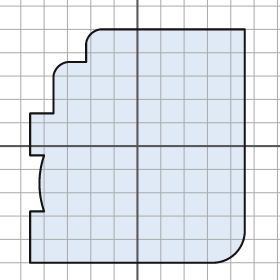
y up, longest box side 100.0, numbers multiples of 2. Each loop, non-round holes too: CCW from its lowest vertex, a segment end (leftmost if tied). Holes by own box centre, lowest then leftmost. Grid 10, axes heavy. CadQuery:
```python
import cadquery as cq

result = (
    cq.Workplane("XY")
    .moveTo(-46.0, -50.0)
    .lineTo(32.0, -50.0)
    .threePointArc((42.0, -46.0), (46.0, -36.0))
    .lineTo(46.0, 50.0)
    .lineTo(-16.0, 50.0)
    .threePointArc((-20.0, 48.0), (-22.0, 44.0))
    .lineTo(-22.0, 36.0)
    .lineTo(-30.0, 36.0)
    .threePointArc((-34.0, 34.0), (-36.0, 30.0))
    .lineTo(-36.0, 14.0)
    .lineTo(-46.0, 14.0)
    .lineTo(-46.0, -4.0)
    .lineTo(-40.0, -4.0)
    .threePointArc((-42.0, -16.0), (-40.0, -28.0))
    .lineTo(-46.0, -28.0)
    .close()
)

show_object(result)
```